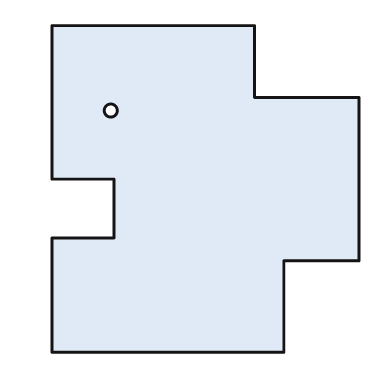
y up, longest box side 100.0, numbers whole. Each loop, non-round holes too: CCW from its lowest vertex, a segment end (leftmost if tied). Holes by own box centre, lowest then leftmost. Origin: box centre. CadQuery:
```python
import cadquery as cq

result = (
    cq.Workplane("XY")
    .moveTo(-47.0, -50.0)
    .lineTo(24.0, -50.0)
    .lineTo(24.0, -22.0)
    .lineTo(47.0, -22.0)
    .lineTo(47.0, 28.0)
    .lineTo(15.0, 28.0)
    .lineTo(15.0, 50.0)
    .lineTo(-47.0, 50.0)
    .lineTo(-47.0, 3.0)
    .lineTo(-28.0, 3.0)
    .lineTo(-28.0, -15.0)
    .lineTo(-47.0, -15.0)
    .close()
    .moveTo(-29.0, 24.0)
    .circle(2.0)
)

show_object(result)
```